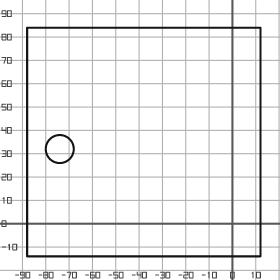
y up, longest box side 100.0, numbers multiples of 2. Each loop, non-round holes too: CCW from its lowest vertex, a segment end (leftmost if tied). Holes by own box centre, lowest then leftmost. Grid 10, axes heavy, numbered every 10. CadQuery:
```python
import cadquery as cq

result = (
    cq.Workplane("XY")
    .moveTo(-88.0, -14.0)
    .lineTo(12.0, -14.0)
    .lineTo(12.0, 84.0)
    .lineTo(-88.0, 84.0)
    .close()
    .moveTo(-74.0, 32.0)
    .circle(6.0)
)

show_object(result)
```